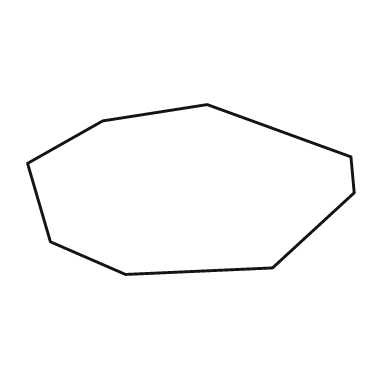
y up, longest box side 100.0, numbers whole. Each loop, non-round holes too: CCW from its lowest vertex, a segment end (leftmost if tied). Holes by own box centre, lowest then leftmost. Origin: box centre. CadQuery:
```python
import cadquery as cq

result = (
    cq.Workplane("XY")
    .moveTo(-20.0, -26.0)
    .lineTo(25.0, -24.0)
    .lineTo(50.0, -1.0)
    .lineTo(49.0, 10.0)
    .lineTo(5.0, 26.0)
    .lineTo(-27.0, 21.0)
    .lineTo(-50.0, 8.0)
    .lineTo(-43.0, -16.0)
    .close()
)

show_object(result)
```